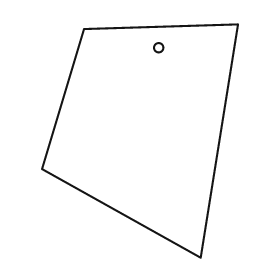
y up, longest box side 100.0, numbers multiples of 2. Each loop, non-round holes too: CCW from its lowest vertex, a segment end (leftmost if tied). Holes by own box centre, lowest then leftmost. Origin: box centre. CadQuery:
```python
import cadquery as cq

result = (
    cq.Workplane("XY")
    .moveTo(26.0, -50.0)
    .lineTo(42.0, 50.0)
    .lineTo(-24.0, 48.0)
    .lineTo(-42.0, -12.0)
    .close()
    .moveTo(8.0, 40.0)
    .circle(2.0)
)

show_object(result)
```